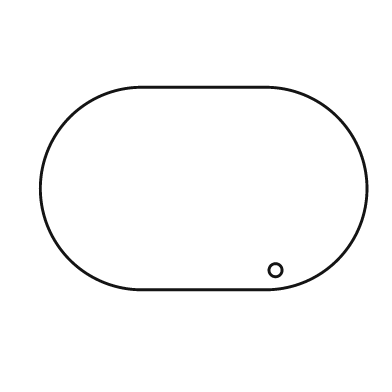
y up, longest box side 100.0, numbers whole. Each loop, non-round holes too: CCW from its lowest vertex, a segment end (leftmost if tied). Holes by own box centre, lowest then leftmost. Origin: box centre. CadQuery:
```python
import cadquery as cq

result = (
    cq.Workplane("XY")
    .moveTo(-19.0, -31.0)
    .lineTo(19.0, -31.0)
    .threePointArc((50.0, 0.0), (19.0, 31.0))
    .lineTo(-19.0, 31.0)
    .threePointArc((-50.0, 0.0), (-19.0, -31.0))
    .close()
    .moveTo(22.0, -25.0)
    .circle(2.0)
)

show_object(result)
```